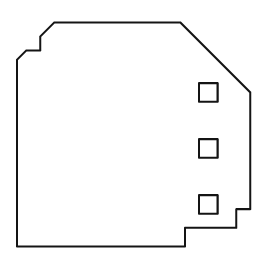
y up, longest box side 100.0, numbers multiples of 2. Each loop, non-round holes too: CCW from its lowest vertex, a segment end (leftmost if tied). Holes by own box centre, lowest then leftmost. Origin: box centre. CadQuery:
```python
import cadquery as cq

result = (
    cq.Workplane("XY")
    .moveTo(-50.0, -48.0)
    .lineTo(22.0, -48.0)
    .lineTo(22.0, -40.0)
    .lineTo(44.0, -40.0)
    .lineTo(44.0, -32.0)
    .lineTo(50.0, -32.0)
    .lineTo(50.0, 18.0)
    .lineTo(20.0, 48.0)
    .lineTo(-34.0, 48.0)
    .lineTo(-40.0, 42.0)
    .lineTo(-40.0, 36.0)
    .lineTo(-46.0, 36.0)
    .lineTo(-50.0, 32.0)
    .close()
    .moveTo(28.0, -34.0)
    .lineTo(36.0, -34.0)
    .lineTo(36.0, -26.0)
    .lineTo(28.0, -26.0)
    .close()
    .moveTo(28.0, -10.0)
    .lineTo(36.0, -10.0)
    .lineTo(36.0, -2.0)
    .lineTo(28.0, -2.0)
    .close()
    .moveTo(28.0, 14.0)
    .lineTo(36.0, 14.0)
    .lineTo(36.0, 22.0)
    .lineTo(28.0, 22.0)
    .close()
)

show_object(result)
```